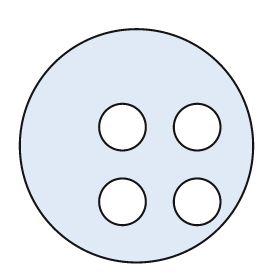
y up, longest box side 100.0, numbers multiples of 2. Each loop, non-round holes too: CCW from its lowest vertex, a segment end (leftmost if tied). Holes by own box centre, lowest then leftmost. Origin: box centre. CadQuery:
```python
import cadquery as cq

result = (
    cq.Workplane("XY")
    .moveTo(0.0, 0.0)
    .circle(50.0)
    .moveTo(-6.0, -24.0)
    .circle(10.0)
    .moveTo(26.0, -24.0)
    .circle(10.0)
    .moveTo(-6.0, 8.0)
    .circle(10.0)
    .moveTo(26.0, 8.0)
    .circle(10.0)
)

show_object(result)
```